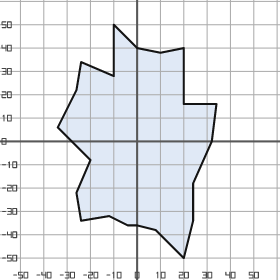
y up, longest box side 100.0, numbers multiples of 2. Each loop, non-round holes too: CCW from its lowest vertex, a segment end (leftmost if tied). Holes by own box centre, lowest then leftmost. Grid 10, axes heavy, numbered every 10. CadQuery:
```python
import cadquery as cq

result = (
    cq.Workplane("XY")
    .moveTo(20.0, -50.0)
    .lineTo(24.0, -34.0)
    .lineTo(24.0, -18.0)
    .lineTo(32.0, 0.0)
    .lineTo(34.0, 16.0)
    .lineTo(20.0, 16.0)
    .lineTo(20.0, 40.0)
    .lineTo(10.0, 38.0)
    .lineTo(0.0, 40.0)
    .lineTo(-10.0, 50.0)
    .lineTo(-10.0, 28.0)
    .lineTo(-24.0, 34.0)
    .lineTo(-26.0, 22.0)
    .lineTo(-34.0, 6.0)
    .lineTo(-20.0, -8.0)
    .lineTo(-26.0, -22.0)
    .lineTo(-24.0, -34.0)
    .lineTo(-12.0, -32.0)
    .lineTo(-4.0, -36.0)
    .lineTo(0.0, -36.0)
    .lineTo(8.0, -38.0)
    .close()
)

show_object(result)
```